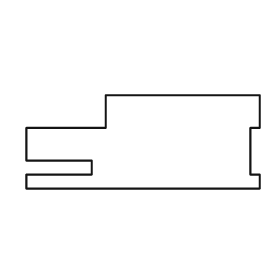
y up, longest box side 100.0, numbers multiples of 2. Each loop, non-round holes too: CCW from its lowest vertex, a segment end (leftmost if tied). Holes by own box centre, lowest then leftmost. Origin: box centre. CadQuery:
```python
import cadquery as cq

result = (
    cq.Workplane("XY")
    .moveTo(-50.0, -20.0)
    .lineTo(50.0, -20.0)
    .lineTo(50.0, -14.0)
    .lineTo(46.0, -14.0)
    .lineTo(46.0, 6.0)
    .lineTo(50.0, 6.0)
    .lineTo(50.0, 20.0)
    .lineTo(-16.0, 20.0)
    .lineTo(-16.0, 6.0)
    .lineTo(-50.0, 6.0)
    .lineTo(-50.0, -8.0)
    .lineTo(-22.0, -8.0)
    .lineTo(-22.0, -14.0)
    .lineTo(-50.0, -14.0)
    .close()
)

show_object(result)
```